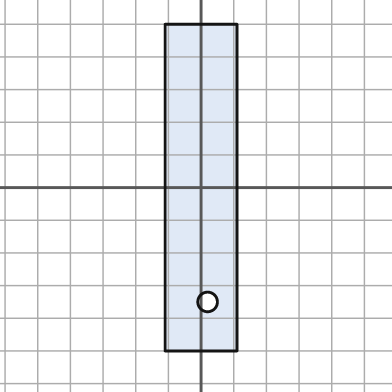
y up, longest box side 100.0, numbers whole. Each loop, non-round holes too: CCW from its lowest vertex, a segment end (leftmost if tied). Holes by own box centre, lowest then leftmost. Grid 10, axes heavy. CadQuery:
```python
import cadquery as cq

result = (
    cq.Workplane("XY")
    .moveTo(-11.0, -50.0)
    .lineTo(11.0, -50.0)
    .lineTo(11.0, 50.0)
    .lineTo(-11.0, 50.0)
    .close()
    .moveTo(2.0, -35.0)
    .circle(3.0)
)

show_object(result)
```